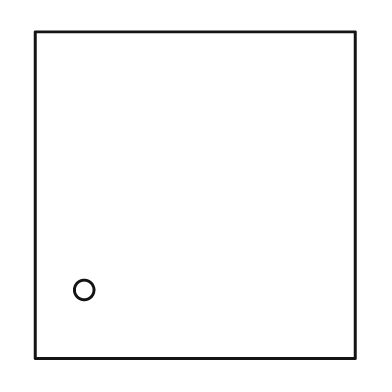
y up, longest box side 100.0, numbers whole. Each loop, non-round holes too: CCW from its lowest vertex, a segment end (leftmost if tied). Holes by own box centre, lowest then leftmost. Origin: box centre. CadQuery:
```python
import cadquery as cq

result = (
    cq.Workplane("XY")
    .moveTo(-49.0, -50.0)
    .lineTo(49.0, -50.0)
    .lineTo(49.0, 50.0)
    .lineTo(-49.0, 50.0)
    .close()
    .moveTo(-34.0, -29.0)
    .circle(3.0)
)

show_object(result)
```